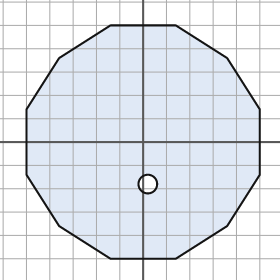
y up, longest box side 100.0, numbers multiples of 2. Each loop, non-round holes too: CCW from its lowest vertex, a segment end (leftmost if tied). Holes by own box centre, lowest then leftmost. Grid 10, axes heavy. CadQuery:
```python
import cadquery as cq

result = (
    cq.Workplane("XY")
    .moveTo(-14.0, -50.0)
    .lineTo(14.0, -50.0)
    .lineTo(36.0, -36.0)
    .lineTo(50.0, -14.0)
    .lineTo(50.0, 14.0)
    .lineTo(36.0, 36.0)
    .lineTo(14.0, 50.0)
    .lineTo(-14.0, 50.0)
    .lineTo(-36.0, 36.0)
    .lineTo(-50.0, 14.0)
    .lineTo(-50.0, -14.0)
    .lineTo(-36.0, -36.0)
    .close()
    .moveTo(2.0, -18.0)
    .circle(4.0)
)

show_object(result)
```